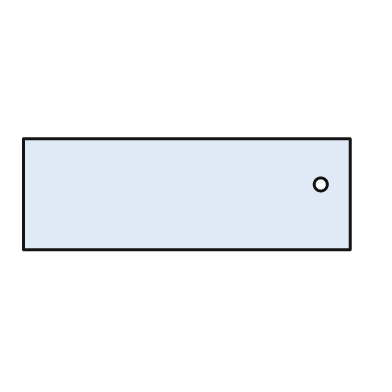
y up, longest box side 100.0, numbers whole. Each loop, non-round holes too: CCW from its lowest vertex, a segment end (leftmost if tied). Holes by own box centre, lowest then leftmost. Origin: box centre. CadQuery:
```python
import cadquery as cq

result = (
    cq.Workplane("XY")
    .moveTo(-50.0, -17.0)
    .lineTo(50.0, -17.0)
    .lineTo(50.0, 17.0)
    .lineTo(-50.0, 17.0)
    .close()
    .moveTo(41.0, 3.0)
    .circle(2.0)
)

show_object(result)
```